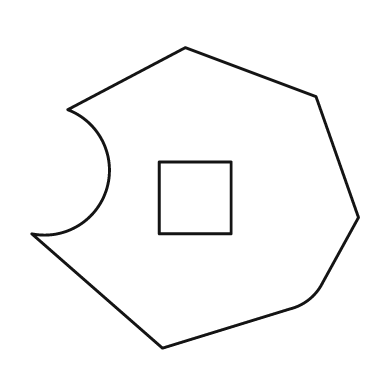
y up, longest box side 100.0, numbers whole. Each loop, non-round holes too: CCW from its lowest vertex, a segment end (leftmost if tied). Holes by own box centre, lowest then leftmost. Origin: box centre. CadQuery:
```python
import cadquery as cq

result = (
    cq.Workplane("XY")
    .moveTo(-10.0, -46.0)
    .lineTo(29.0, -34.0)
    .threePointArc((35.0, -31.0), (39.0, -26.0))
    .lineTo(50.0, -6.0)
    .lineTo(37.0, 31.0)
    .lineTo(-3.0, 46.0)
    .lineTo(-39.0, 27.0)
    .threePointArc((-27.0, 3.0), (-50.0, -11.0))
    .close()
    .moveTo(-11.0, -11.0)
    .lineTo(11.0, -11.0)
    .lineTo(11.0, 11.0)
    .lineTo(-11.0, 11.0)
    .close()
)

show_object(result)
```